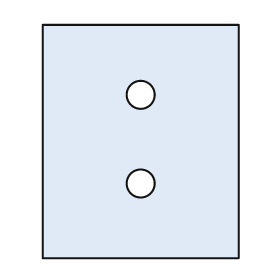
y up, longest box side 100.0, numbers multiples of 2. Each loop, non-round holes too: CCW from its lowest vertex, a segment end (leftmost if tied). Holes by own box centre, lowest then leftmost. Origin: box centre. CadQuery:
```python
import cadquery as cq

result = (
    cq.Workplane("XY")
    .moveTo(-42.0, -50.0)
    .lineTo(42.0, -50.0)
    .lineTo(42.0, 50.0)
    .lineTo(-42.0, 50.0)
    .close()
    .moveTo(0.0, -18.0)
    .circle(6.0)
    .moveTo(0.0, 20.0)
    .circle(6.0)
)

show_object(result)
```